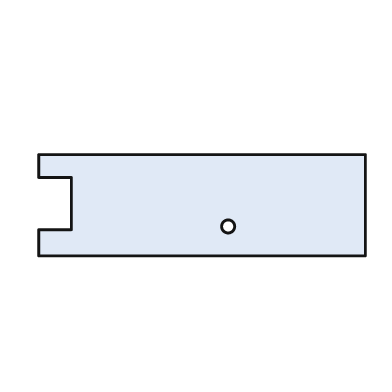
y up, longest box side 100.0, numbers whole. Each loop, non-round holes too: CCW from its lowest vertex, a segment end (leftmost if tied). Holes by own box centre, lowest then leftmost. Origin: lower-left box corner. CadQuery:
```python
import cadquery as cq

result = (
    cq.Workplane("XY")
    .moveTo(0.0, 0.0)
    .lineTo(100.0, 0.0)
    .lineTo(100.0, 31.0)
    .lineTo(0.0, 31.0)
    .lineTo(0.0, 24.0)
    .lineTo(10.0, 24.0)
    .lineTo(10.0, 8.0)
    .lineTo(0.0, 8.0)
    .close()
    .moveTo(58.0, 9.0)
    .circle(2.0)
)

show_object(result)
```